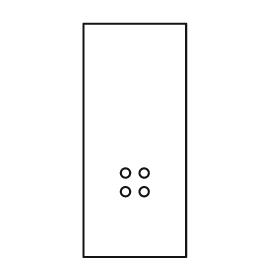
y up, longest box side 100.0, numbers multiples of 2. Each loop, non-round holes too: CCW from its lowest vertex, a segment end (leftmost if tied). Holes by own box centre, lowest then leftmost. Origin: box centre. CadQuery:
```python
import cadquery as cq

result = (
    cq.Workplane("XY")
    .moveTo(-22.0, -50.0)
    .lineTo(22.0, -50.0)
    .lineTo(22.0, 50.0)
    .lineTo(-22.0, 50.0)
    .close()
    .moveTo(-4.0, -22.0)
    .circle(2.0)
    .moveTo(4.0, -22.0)
    .circle(2.0)
    .moveTo(-4.0, -14.0)
    .circle(2.0)
    .moveTo(4.0, -14.0)
    .circle(2.0)
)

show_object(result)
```